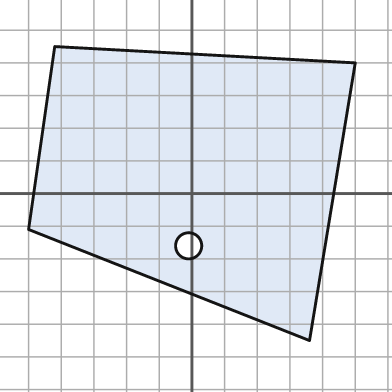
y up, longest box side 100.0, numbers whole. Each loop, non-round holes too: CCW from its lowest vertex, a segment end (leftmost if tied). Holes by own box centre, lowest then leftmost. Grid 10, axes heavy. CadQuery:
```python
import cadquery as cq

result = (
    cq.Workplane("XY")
    .moveTo(36.0, -45.0)
    .lineTo(50.0, 40.0)
    .lineTo(-42.0, 45.0)
    .lineTo(-50.0, -11.0)
    .close()
    .moveTo(-1.0, -16.0)
    .circle(4.0)
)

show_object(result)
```